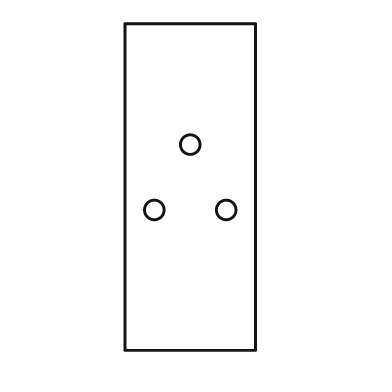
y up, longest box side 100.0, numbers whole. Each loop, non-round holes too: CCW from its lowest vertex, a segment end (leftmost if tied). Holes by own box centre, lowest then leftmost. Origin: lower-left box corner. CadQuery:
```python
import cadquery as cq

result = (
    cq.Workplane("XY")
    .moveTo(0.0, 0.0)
    .lineTo(40.0, 0.0)
    .lineTo(40.0, 100.0)
    .lineTo(0.0, 100.0)
    .close()
    .moveTo(9.0, 43.0)
    .circle(3.0)
    .moveTo(31.0, 43.0)
    .circle(3.0)
    .moveTo(20.0, 63.0)
    .circle(3.0)
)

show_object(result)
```